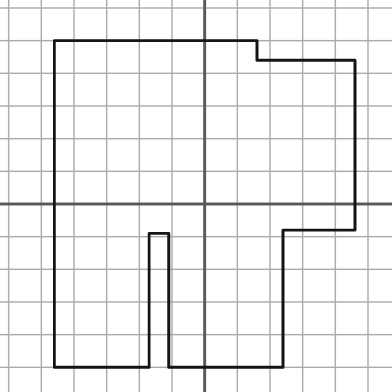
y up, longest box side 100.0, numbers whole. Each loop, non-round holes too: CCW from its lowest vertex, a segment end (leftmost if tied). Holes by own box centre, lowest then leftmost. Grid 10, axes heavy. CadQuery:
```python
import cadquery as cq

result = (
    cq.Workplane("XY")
    .moveTo(-46.0, -50.0)
    .lineTo(-17.0, -50.0)
    .lineTo(-17.0, -9.0)
    .lineTo(-11.0, -9.0)
    .lineTo(-11.0, -50.0)
    .lineTo(24.0, -50.0)
    .lineTo(24.0, -8.0)
    .lineTo(46.0, -8.0)
    .lineTo(46.0, 44.0)
    .lineTo(16.0, 44.0)
    .lineTo(16.0, 50.0)
    .lineTo(-46.0, 50.0)
    .close()
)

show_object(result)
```